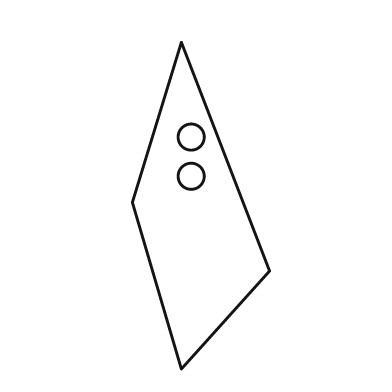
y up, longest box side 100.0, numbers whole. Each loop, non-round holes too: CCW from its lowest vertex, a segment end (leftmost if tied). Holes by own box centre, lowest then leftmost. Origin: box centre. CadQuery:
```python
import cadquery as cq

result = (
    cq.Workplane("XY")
    .moveTo(-6.0, -50.0)
    .lineTo(21.0, -20.0)
    .lineTo(-6.0, 50.0)
    .lineTo(-21.0, 1.0)
    .close()
    .moveTo(-3.0, 9.0)
    .circle(4.0)
    .moveTo(-3.0, 21.0)
    .circle(4.0)
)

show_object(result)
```